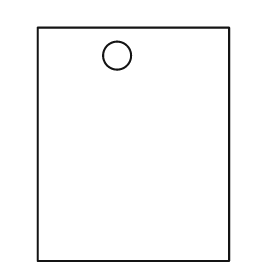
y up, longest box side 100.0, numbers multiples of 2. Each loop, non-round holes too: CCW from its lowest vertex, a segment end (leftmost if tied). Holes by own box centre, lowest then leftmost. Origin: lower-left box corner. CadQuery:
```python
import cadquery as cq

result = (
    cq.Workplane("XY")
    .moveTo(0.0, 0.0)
    .lineTo(82.0, 0.0)
    .lineTo(82.0, 100.0)
    .lineTo(0.0, 100.0)
    .close()
    .moveTo(34.0, 88.0)
    .circle(6.0)
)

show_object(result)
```